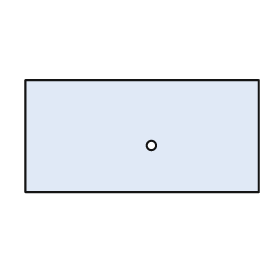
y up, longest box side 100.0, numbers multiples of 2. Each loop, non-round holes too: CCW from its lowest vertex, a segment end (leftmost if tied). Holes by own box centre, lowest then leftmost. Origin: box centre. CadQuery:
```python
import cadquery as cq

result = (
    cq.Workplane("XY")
    .moveTo(-50.0, -24.0)
    .lineTo(50.0, -24.0)
    .lineTo(50.0, 24.0)
    .lineTo(-50.0, 24.0)
    .close()
    .moveTo(4.0, -4.0)
    .circle(2.0)
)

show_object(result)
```